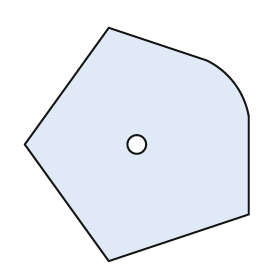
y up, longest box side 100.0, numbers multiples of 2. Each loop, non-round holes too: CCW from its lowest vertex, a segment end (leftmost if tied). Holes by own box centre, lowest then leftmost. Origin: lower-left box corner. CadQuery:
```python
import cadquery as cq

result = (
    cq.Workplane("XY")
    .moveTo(36.0, 0.0)
    .lineTo(96.0, 20.0)
    .lineTo(96.0, 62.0)
    .threePointArc((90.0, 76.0), (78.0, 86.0))
    .lineTo(36.0, 100.0)
    .lineTo(0.0, 50.0)
    .close()
    .moveTo(48.0, 50.0)
    .circle(4.0)
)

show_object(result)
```